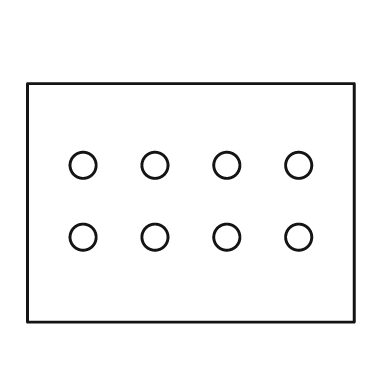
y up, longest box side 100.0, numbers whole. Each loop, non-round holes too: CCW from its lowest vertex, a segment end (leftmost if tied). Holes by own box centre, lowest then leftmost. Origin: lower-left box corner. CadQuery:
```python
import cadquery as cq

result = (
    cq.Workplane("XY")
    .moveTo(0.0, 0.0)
    .lineTo(100.0, 0.0)
    .lineTo(100.0, 73.0)
    .lineTo(0.0, 73.0)
    .close()
    .moveTo(17.0, 26.0)
    .circle(4.0)
    .moveTo(39.0, 26.0)
    .circle(4.0)
    .moveTo(61.0, 26.0)
    .circle(4.0)
    .moveTo(83.0, 26.0)
    .circle(4.0)
    .moveTo(17.0, 48.0)
    .circle(4.0)
    .moveTo(39.0, 48.0)
    .circle(4.0)
    .moveTo(61.0, 48.0)
    .circle(4.0)
    .moveTo(83.0, 48.0)
    .circle(4.0)
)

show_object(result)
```